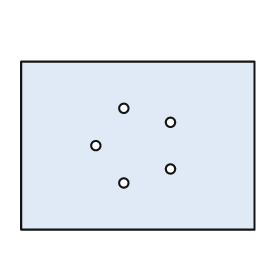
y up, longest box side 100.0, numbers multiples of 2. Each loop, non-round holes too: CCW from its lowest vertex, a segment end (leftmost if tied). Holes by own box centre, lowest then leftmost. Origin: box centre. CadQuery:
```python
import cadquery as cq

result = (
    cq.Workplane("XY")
    .moveTo(-50.0, -36.0)
    .lineTo(50.0, -36.0)
    .lineTo(50.0, 36.0)
    .lineTo(-50.0, 36.0)
    .close()
    .moveTo(-6.0, -16.0)
    .circle(2.0)
    .moveTo(14.0, -10.0)
    .circle(2.0)
    .moveTo(-18.0, 0.0)
    .circle(2.0)
    .moveTo(14.0, 10.0)
    .circle(2.0)
    .moveTo(-6.0, 16.0)
    .circle(2.0)
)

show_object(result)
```